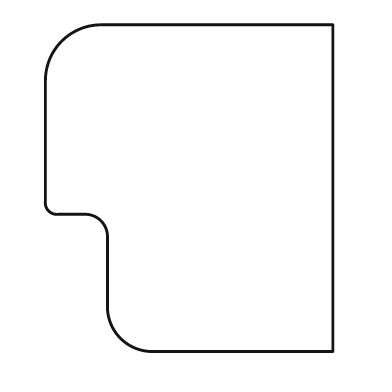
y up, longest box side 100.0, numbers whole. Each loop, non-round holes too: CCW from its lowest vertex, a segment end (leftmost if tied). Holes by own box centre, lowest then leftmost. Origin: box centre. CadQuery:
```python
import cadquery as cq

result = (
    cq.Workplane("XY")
    .moveTo(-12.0, -50.0)
    .lineTo(44.0, -50.0)
    .lineTo(44.0, 50.0)
    .lineTo(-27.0, 50.0)
    .threePointArc((-39.0, 45.0), (-44.0, 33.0))
    .lineTo(-44.0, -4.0)
    .threePointArc((-43.0, -7.0), (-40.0, -8.0))
    .lineTo(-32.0, -8.0)
    .threePointArc((-27.0, -10.0), (-25.0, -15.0))
    .lineTo(-25.0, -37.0)
    .threePointArc((-21.0, -46.0), (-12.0, -50.0))
    .close()
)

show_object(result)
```